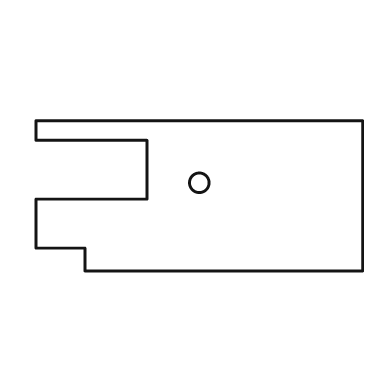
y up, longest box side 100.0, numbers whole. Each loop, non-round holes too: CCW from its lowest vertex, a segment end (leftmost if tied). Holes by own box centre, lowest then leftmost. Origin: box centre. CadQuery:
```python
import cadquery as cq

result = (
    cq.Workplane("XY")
    .moveTo(-35.0, -23.0)
    .lineTo(50.0, -23.0)
    .lineTo(50.0, 23.0)
    .lineTo(-50.0, 23.0)
    .lineTo(-50.0, 17.0)
    .lineTo(-16.0, 17.0)
    .lineTo(-16.0, -1.0)
    .lineTo(-50.0, -1.0)
    .lineTo(-50.0, -16.0)
    .lineTo(-35.0, -16.0)
    .close()
    .moveTo(0.0, 4.0)
    .circle(3.0)
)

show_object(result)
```